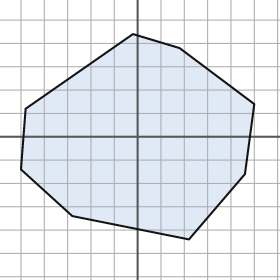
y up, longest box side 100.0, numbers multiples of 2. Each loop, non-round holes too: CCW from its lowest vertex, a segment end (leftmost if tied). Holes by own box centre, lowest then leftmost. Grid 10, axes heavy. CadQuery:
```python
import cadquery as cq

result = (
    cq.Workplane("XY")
    .moveTo(22.0, -44.0)
    .lineTo(46.0, -16.0)
    .lineTo(50.0, 14.0)
    .lineTo(18.0, 38.0)
    .lineTo(-2.0, 44.0)
    .lineTo(-48.0, 12.0)
    .lineTo(-50.0, -14.0)
    .lineTo(-28.0, -34.0)
    .close()
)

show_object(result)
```